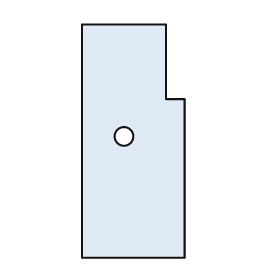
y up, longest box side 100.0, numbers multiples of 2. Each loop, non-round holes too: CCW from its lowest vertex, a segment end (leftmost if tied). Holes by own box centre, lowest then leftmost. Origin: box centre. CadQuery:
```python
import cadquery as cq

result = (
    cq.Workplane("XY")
    .moveTo(-22.0, -50.0)
    .lineTo(22.0, -50.0)
    .lineTo(22.0, 18.0)
    .lineTo(14.0, 18.0)
    .lineTo(14.0, 50.0)
    .lineTo(-22.0, 50.0)
    .close()
    .moveTo(-4.0, 2.0)
    .circle(4.0)
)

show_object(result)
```